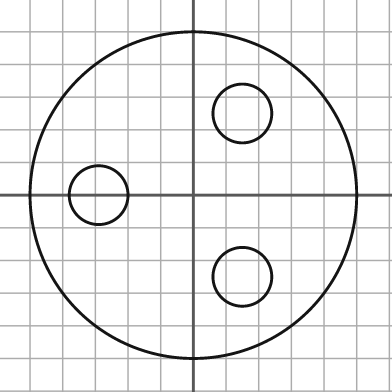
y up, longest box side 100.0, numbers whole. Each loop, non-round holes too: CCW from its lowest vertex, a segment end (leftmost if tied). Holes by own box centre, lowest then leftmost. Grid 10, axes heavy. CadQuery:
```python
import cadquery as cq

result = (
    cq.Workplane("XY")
    .moveTo(0.0, 0.0)
    .circle(50.0)
    .moveTo(15.0, -25.0)
    .circle(9.0)
    .moveTo(-29.0, 0.0)
    .circle(9.0)
    .moveTo(15.0, 25.0)
    .circle(9.0)
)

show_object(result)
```